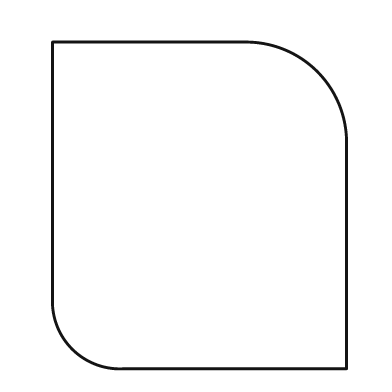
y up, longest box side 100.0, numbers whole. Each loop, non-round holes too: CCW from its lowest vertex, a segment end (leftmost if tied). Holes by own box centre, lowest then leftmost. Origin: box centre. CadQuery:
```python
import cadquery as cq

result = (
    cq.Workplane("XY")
    .moveTo(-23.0, -50.0)
    .lineTo(45.0, -50.0)
    .lineTo(45.0, 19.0)
    .threePointArc((36.0, 41.0), (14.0, 50.0))
    .lineTo(-45.0, 50.0)
    .lineTo(-45.0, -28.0)
    .threePointArc((-39.0, -44.0), (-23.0, -50.0))
    .close()
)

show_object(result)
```